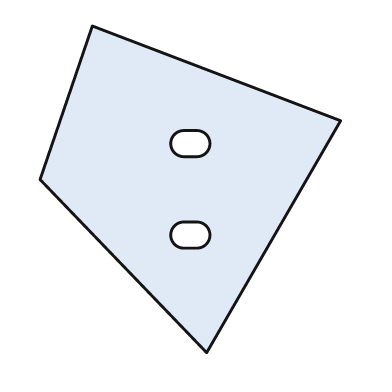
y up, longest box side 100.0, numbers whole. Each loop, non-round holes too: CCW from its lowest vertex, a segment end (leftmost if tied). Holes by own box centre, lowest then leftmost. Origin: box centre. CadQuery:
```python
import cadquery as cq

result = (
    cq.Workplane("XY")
    .moveTo(5.0, -50.0)
    .lineTo(46.0, 21.0)
    .lineTo(-30.0, 50.0)
    .lineTo(-46.0, 3.0)
    .close()
    .moveTo(-2.0, -18.0)
    .lineTo(2.0, -18.0)
    .threePointArc((6.0, -14.0), (2.0, -10.0))
    .lineTo(-2.0, -10.0)
    .threePointArc((-6.0, -14.0), (-2.0, -18.0))
    .close()
    .moveTo(-2.0, 10.0)
    .lineTo(2.0, 10.0)
    .threePointArc((6.0, 14.0), (2.0, 18.0))
    .lineTo(-2.0, 18.0)
    .threePointArc((-6.0, 14.0), (-2.0, 10.0))
    .close()
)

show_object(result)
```